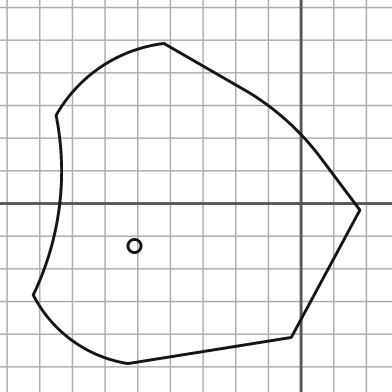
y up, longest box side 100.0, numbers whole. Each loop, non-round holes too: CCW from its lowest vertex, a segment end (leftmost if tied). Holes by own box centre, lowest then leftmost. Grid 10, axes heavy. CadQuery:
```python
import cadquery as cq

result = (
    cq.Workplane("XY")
    .moveTo(-53.0, -49.0)
    .lineTo(-3.0, -41.0)
    .lineTo(18.0, -2.0)
    .lineTo(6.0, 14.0)
    .threePointArc((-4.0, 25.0), (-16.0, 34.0))
    .lineTo(-42.0, 49.0)
    .threePointArc((-61.0, 42.0), (-75.0, 27.0))
    .threePointArc((-74.0, -1.0), (-82.0, -28.0))
    .threePointArc((-70.0, -42.0), (-53.0, -49.0))
    .close()
    .moveTo(-51.0, -13.0)
    .circle(2.0)
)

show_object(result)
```